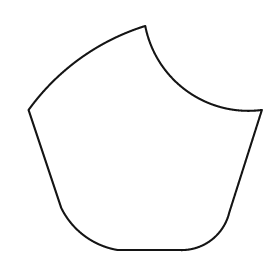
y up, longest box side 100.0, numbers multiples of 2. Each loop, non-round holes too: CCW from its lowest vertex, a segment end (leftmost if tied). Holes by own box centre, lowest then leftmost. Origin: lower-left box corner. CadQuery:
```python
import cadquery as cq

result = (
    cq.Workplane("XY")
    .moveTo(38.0, 0.0)
    .lineTo(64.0, 0.0)
    .threePointArc((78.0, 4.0), (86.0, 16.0))
    .lineTo(100.0, 60.0)
    .threePointArc((68.0, 68.0), (50.0, 96.0))
    .threePointArc((22.0, 82.0), (0.0, 60.0))
    .lineTo(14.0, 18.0)
    .threePointArc((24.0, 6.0), (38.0, 0.0))
    .close()
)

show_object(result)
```